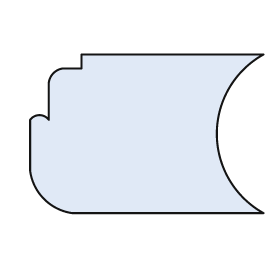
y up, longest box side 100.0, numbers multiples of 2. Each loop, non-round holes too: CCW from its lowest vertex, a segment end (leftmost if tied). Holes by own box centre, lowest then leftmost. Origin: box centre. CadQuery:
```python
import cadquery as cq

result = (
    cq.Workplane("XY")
    .moveTo(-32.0, -34.0)
    .lineTo(50.0, -34.0)
    .threePointArc((30.0, 0.0), (50.0, 34.0))
    .lineTo(-28.0, 34.0)
    .lineTo(-28.0, 28.0)
    .lineTo(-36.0, 28.0)
    .threePointArc((-40.0, 26.0), (-42.0, 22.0))
    .lineTo(-42.0, 6.0)
    .threePointArc((-46.0, 8.0), (-50.0, 6.0))
    .lineTo(-50.0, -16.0)
    .threePointArc((-44.0, -28.0), (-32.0, -34.0))
    .close()
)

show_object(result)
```